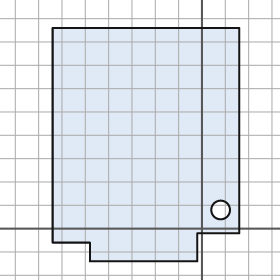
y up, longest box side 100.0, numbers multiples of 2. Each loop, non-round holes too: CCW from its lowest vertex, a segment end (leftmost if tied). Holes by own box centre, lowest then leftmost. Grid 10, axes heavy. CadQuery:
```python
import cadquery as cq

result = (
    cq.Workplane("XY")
    .moveTo(-48.0, -14.0)
    .lineTo(-2.0, -14.0)
    .lineTo(-2.0, -2.0)
    .lineTo(16.0, -2.0)
    .lineTo(16.0, 86.0)
    .lineTo(-64.0, 86.0)
    .lineTo(-64.0, -6.0)
    .lineTo(-48.0, -6.0)
    .close()
    .moveTo(8.0, 8.0)
    .circle(4.0)
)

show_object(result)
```